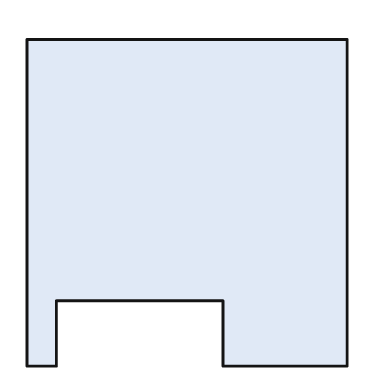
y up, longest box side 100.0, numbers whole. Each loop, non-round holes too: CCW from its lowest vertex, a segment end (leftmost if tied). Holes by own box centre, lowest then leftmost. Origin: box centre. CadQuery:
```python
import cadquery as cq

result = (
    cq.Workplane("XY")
    .moveTo(-49.0, -50.0)
    .lineTo(-40.0, -50.0)
    .lineTo(-40.0, -30.0)
    .lineTo(11.0, -30.0)
    .lineTo(11.0, -50.0)
    .lineTo(49.0, -50.0)
    .lineTo(49.0, 50.0)
    .lineTo(-49.0, 50.0)
    .close()
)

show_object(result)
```